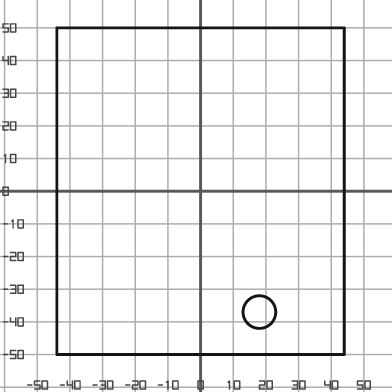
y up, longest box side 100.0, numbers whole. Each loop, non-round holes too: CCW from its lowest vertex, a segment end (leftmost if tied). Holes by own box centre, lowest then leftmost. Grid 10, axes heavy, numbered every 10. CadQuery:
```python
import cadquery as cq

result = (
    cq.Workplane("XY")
    .moveTo(-44.0, -50.0)
    .lineTo(44.0, -50.0)
    .lineTo(44.0, 50.0)
    .lineTo(-44.0, 50.0)
    .close()
    .moveTo(18.0, -37.0)
    .circle(5.0)
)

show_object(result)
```